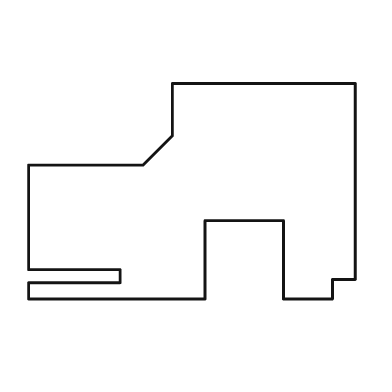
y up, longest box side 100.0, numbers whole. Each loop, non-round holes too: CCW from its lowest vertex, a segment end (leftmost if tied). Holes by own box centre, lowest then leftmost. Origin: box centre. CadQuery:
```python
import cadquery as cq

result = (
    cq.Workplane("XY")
    .moveTo(-50.0, -33.0)
    .lineTo(4.0, -33.0)
    .lineTo(4.0, -9.0)
    .lineTo(28.0, -9.0)
    .lineTo(28.0, -33.0)
    .lineTo(43.0, -33.0)
    .lineTo(43.0, -27.0)
    .lineTo(50.0, -27.0)
    .lineTo(50.0, 33.0)
    .lineTo(-6.0, 33.0)
    .lineTo(-6.0, 17.0)
    .lineTo(-15.0, 8.0)
    .lineTo(-50.0, 8.0)
    .lineTo(-50.0, -24.0)
    .lineTo(-22.0, -24.0)
    .lineTo(-22.0, -28.0)
    .lineTo(-50.0, -28.0)
    .close()
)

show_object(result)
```